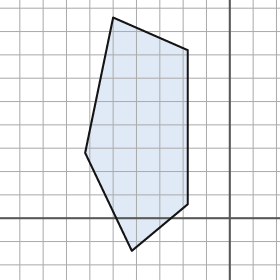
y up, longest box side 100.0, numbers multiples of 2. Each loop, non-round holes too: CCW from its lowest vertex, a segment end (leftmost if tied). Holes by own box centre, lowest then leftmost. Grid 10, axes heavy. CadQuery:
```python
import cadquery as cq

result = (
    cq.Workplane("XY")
    .moveTo(-42.0, -14.0)
    .lineTo(-18.0, 6.0)
    .lineTo(-18.0, 72.0)
    .lineTo(-50.0, 86.0)
    .lineTo(-62.0, 28.0)
    .close()
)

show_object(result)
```